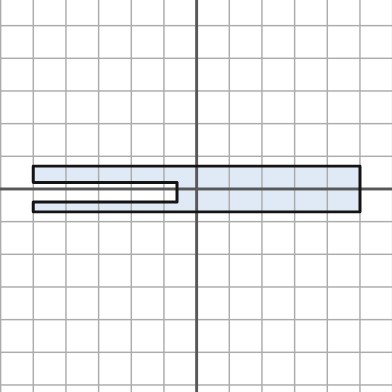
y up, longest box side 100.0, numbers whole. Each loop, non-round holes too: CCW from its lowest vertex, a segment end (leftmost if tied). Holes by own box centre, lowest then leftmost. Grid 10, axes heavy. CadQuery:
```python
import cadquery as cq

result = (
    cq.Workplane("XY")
    .moveTo(-50.0, -7.0)
    .lineTo(50.0, -7.0)
    .lineTo(50.0, 7.0)
    .lineTo(-50.0, 7.0)
    .lineTo(-50.0, 2.0)
    .lineTo(-6.0, 2.0)
    .lineTo(-6.0, -4.0)
    .lineTo(-50.0, -4.0)
    .close()
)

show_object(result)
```